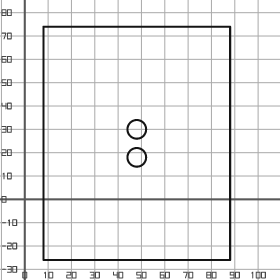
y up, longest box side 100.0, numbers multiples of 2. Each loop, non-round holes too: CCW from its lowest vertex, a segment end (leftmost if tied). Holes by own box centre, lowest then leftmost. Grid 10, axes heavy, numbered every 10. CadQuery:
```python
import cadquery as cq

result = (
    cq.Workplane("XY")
    .moveTo(8.0, -26.0)
    .lineTo(88.0, -26.0)
    .lineTo(88.0, 74.0)
    .lineTo(8.0, 74.0)
    .close()
    .moveTo(48.0, 18.0)
    .circle(4.0)
    .moveTo(48.0, 30.0)
    .circle(4.0)
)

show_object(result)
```